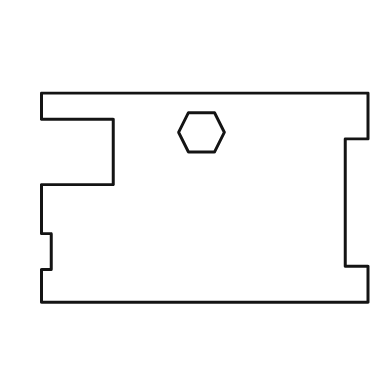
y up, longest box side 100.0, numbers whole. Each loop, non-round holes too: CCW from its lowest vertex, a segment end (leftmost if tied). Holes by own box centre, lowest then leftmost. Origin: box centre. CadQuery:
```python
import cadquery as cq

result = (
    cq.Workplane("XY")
    .moveTo(-50.0, -32.0)
    .lineTo(50.0, -32.0)
    .lineTo(50.0, -21.0)
    .lineTo(43.0, -21.0)
    .lineTo(43.0, 18.0)
    .lineTo(50.0, 18.0)
    .lineTo(50.0, 32.0)
    .lineTo(-50.0, 32.0)
    .lineTo(-50.0, 24.0)
    .lineTo(-28.0, 24.0)
    .lineTo(-28.0, 4.0)
    .lineTo(-50.0, 4.0)
    .lineTo(-50.0, -11.0)
    .lineTo(-47.0, -11.0)
    .lineTo(-47.0, -22.0)
    .lineTo(-50.0, -22.0)
    .close()
    .moveTo(-5.0, 14.0)
    .lineTo(3.0, 14.0)
    .lineTo(6.0, 20.0)
    .lineTo(3.0, 26.0)
    .lineTo(-5.0, 26.0)
    .lineTo(-8.0, 20.0)
    .close()
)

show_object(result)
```